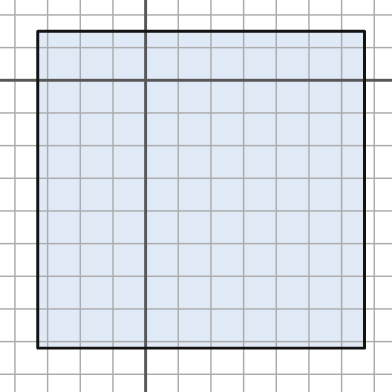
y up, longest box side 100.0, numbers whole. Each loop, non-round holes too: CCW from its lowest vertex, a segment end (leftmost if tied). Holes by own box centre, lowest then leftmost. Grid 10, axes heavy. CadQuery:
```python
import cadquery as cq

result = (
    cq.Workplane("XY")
    .moveTo(-33.0, -82.0)
    .lineTo(67.0, -82.0)
    .lineTo(67.0, 15.0)
    .lineTo(-33.0, 15.0)
    .close()
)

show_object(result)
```